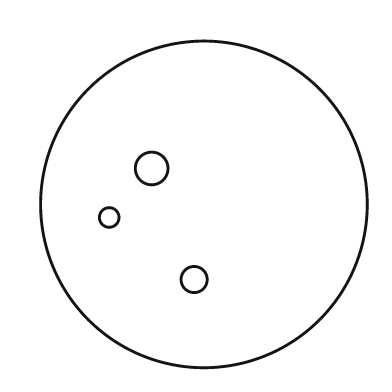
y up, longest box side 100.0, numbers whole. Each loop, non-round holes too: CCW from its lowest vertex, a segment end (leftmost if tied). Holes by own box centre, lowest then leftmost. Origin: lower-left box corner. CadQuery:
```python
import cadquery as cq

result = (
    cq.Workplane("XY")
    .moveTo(50.0, 50.0)
    .circle(50.0)
    .moveTo(47.0, 27.0)
    .circle(4.0)
    .moveTo(21.0, 46.0)
    .circle(3.0)
    .moveTo(34.0, 61.0)
    .circle(5.0)
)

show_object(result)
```